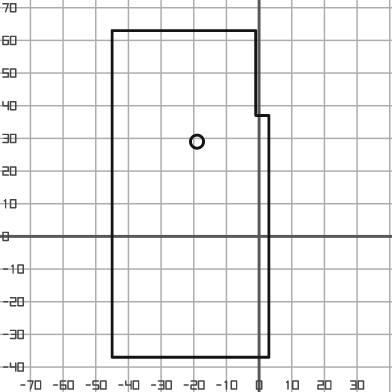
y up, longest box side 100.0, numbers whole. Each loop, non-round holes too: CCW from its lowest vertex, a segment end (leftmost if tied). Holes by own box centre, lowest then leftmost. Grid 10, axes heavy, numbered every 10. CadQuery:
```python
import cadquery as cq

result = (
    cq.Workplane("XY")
    .moveTo(-45.0, -37.0)
    .lineTo(3.0, -37.0)
    .lineTo(3.0, 37.0)
    .lineTo(-1.0, 37.0)
    .lineTo(-1.0, 63.0)
    .lineTo(-45.0, 63.0)
    .close()
    .moveTo(-19.0, 29.0)
    .circle(2.0)
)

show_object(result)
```